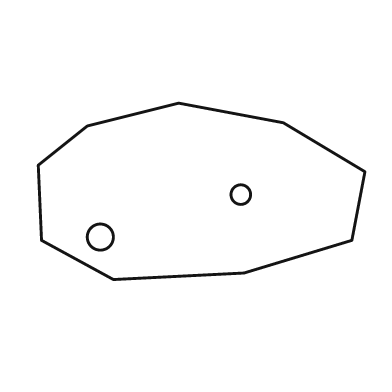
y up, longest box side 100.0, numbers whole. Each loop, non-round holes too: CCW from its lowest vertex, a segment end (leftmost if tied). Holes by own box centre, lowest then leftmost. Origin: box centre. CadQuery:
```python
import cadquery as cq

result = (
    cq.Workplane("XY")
    .moveTo(-27.0, -27.0)
    .lineTo(13.0, -25.0)
    .lineTo(46.0, -15.0)
    .lineTo(50.0, 6.0)
    .lineTo(25.0, 21.0)
    .lineTo(-7.0, 27.0)
    .lineTo(-35.0, 20.0)
    .lineTo(-50.0, 8.0)
    .lineTo(-49.0, -15.0)
    .close()
    .moveTo(-31.0, -14.0)
    .circle(4.0)
    .moveTo(12.0, -1.0)
    .circle(3.0)
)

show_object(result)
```